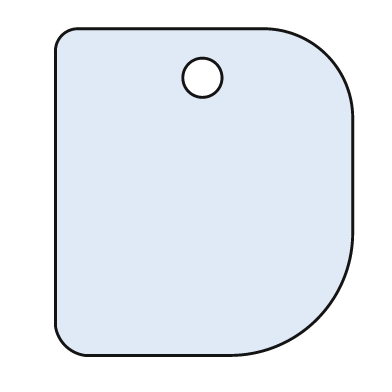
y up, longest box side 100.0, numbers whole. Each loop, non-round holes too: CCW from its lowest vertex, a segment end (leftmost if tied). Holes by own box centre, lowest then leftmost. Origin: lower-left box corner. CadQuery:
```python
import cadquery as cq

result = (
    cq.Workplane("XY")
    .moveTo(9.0, 0.0)
    .lineTo(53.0, 0.0)
    .threePointArc((80.0, 11.0), (91.0, 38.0))
    .lineTo(91.0, 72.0)
    .threePointArc((83.0, 92.0), (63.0, 100.0))
    .lineTo(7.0, 100.0)
    .threePointArc((2.0, 98.0), (0.0, 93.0))
    .lineTo(0.0, 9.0)
    .threePointArc((3.0, 3.0), (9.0, 0.0))
    .close()
    .moveTo(45.0, 85.0)
    .circle(6.0)
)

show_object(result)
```